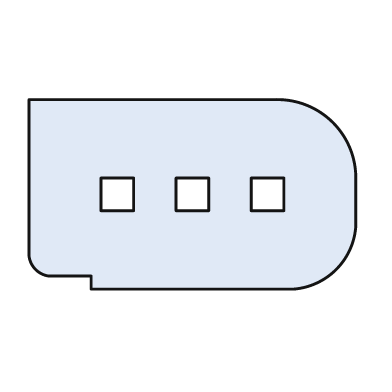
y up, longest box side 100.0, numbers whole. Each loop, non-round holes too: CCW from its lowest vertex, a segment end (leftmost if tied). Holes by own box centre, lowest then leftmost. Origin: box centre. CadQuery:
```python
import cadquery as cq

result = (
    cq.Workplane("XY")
    .moveTo(-31.0, -29.0)
    .lineTo(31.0, -29.0)
    .threePointArc((44.0, -23.0), (50.0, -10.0))
    .lineTo(50.0, 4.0)
    .threePointArc((43.0, 22.0), (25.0, 29.0))
    .lineTo(-50.0, 29.0)
    .lineTo(-50.0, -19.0)
    .threePointArc((-48.0, -23.0), (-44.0, -25.0))
    .lineTo(-31.0, -25.0)
    .close()
    .moveTo(-28.0, -5.0)
    .lineTo(-18.0, -5.0)
    .lineTo(-18.0, 5.0)
    .lineTo(-28.0, 5.0)
    .close()
    .moveTo(-5.0, -5.0)
    .lineTo(5.0, -5.0)
    .lineTo(5.0, 5.0)
    .lineTo(-5.0, 5.0)
    .close()
    .moveTo(18.0, -5.0)
    .lineTo(28.0, -5.0)
    .lineTo(28.0, 5.0)
    .lineTo(18.0, 5.0)
    .close()
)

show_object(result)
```